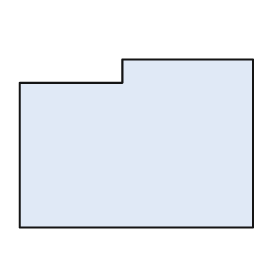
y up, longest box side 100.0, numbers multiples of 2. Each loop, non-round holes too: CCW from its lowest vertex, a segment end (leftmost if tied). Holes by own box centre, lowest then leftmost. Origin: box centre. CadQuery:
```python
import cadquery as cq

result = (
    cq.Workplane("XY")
    .moveTo(-50.0, -36.0)
    .lineTo(50.0, -36.0)
    .lineTo(50.0, 36.0)
    .lineTo(-6.0, 36.0)
    .lineTo(-6.0, 26.0)
    .lineTo(-50.0, 26.0)
    .close()
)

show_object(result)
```